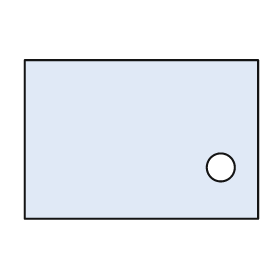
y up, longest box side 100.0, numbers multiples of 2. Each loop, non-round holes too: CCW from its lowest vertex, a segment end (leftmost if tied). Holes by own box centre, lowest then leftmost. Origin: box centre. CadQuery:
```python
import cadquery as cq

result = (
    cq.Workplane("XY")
    .moveTo(-50.0, -34.0)
    .lineTo(50.0, -34.0)
    .lineTo(50.0, 34.0)
    .lineTo(-50.0, 34.0)
    .close()
    .moveTo(34.0, -12.0)
    .circle(6.0)
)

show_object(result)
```